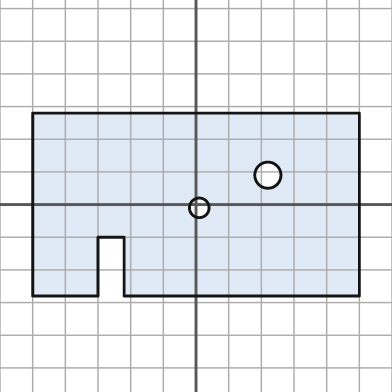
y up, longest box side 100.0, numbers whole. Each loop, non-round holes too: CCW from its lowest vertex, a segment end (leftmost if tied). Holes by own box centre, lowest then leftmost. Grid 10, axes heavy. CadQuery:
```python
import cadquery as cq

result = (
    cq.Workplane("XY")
    .moveTo(-50.0, -28.0)
    .lineTo(-30.0, -28.0)
    .lineTo(-30.0, -10.0)
    .lineTo(-22.0, -10.0)
    .lineTo(-22.0, -28.0)
    .lineTo(50.0, -28.0)
    .lineTo(50.0, 28.0)
    .lineTo(-50.0, 28.0)
    .close()
    .moveTo(1.0, -1.0)
    .circle(3.0)
    .moveTo(22.0, 9.0)
    .circle(4.0)
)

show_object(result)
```